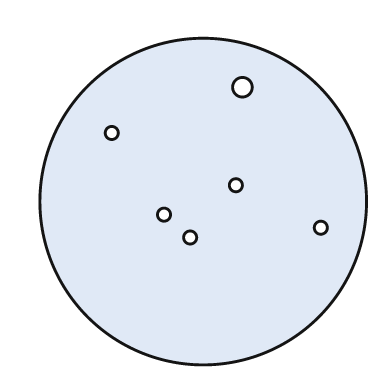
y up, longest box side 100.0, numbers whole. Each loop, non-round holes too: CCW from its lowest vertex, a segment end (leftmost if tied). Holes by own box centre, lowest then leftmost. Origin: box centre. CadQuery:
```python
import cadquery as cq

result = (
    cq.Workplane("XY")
    .moveTo(0.0, 0.0)
    .circle(50.0)
    .moveTo(-4.0, -11.0)
    .circle(2.0)
    .moveTo(36.0, -8.0)
    .circle(2.0)
    .moveTo(-12.0, -4.0)
    .circle(2.0)
    .moveTo(10.0, 5.0)
    .circle(2.0)
    .moveTo(-28.0, 21.0)
    .circle(2.0)
    .moveTo(12.0, 35.0)
    .circle(3.0)
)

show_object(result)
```